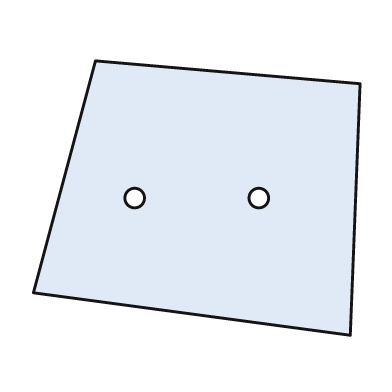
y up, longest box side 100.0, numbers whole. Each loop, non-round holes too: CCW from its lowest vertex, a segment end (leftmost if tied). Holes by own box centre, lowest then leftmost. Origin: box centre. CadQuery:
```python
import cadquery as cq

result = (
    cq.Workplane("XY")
    .moveTo(47.0, -42.0)
    .lineTo(50.0, 35.0)
    .lineTo(-31.0, 42.0)
    .lineTo(-50.0, -29.0)
    .close()
    .moveTo(-19.0, 0.0)
    .circle(3.0)
    .moveTo(19.0, 0.0)
    .circle(3.0)
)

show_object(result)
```